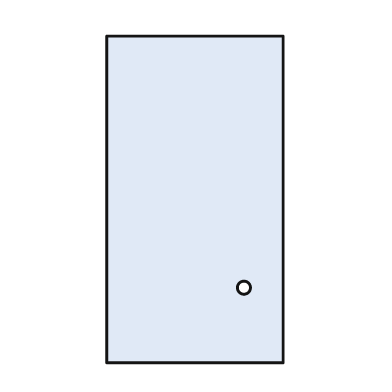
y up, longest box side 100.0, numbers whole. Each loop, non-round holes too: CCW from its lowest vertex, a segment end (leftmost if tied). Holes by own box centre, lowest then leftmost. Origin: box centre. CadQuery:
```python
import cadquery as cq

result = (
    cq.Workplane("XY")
    .moveTo(-27.0, -50.0)
    .lineTo(27.0, -50.0)
    .lineTo(27.0, 50.0)
    .lineTo(-27.0, 50.0)
    .close()
    .moveTo(15.0, -27.0)
    .circle(2.0)
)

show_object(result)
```